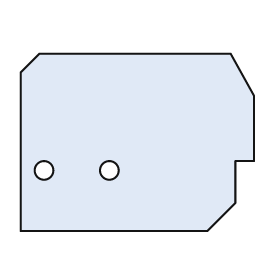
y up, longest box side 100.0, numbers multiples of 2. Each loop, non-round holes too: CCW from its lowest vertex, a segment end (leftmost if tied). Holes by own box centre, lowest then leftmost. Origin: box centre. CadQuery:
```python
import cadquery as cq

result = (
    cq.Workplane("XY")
    .moveTo(-50.0, -38.0)
    .lineTo(30.0, -38.0)
    .lineTo(42.0, -26.0)
    .lineTo(42.0, -8.0)
    .lineTo(50.0, -8.0)
    .lineTo(50.0, 20.0)
    .lineTo(40.0, 38.0)
    .lineTo(-42.0, 38.0)
    .lineTo(-50.0, 30.0)
    .close()
    .moveTo(-40.0, -12.0)
    .circle(4.0)
    .moveTo(-12.0, -12.0)
    .circle(4.0)
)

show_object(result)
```